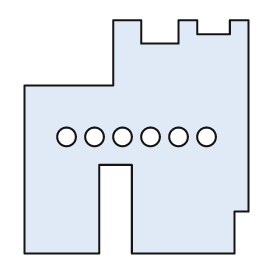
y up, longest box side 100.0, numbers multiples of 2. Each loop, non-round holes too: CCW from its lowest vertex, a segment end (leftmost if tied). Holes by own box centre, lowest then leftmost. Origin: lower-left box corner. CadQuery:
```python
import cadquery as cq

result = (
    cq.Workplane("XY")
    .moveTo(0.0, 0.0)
    .lineTo(32.0, 0.0)
    .lineTo(32.0, 38.0)
    .lineTo(46.0, 38.0)
    .lineTo(46.0, 0.0)
    .lineTo(90.0, 0.0)
    .lineTo(90.0, 18.0)
    .lineTo(96.0, 18.0)
    .lineTo(96.0, 100.0)
    .lineTo(88.0, 100.0)
    .lineTo(88.0, 94.0)
    .lineTo(74.0, 94.0)
    .lineTo(74.0, 100.0)
    .lineTo(66.0, 100.0)
    .lineTo(66.0, 90.0)
    .lineTo(50.0, 90.0)
    .lineTo(50.0, 100.0)
    .lineTo(38.0, 100.0)
    .lineTo(38.0, 72.0)
    .lineTo(0.0, 72.0)
    .close()
    .moveTo(18.0, 50.0)
    .circle(4.0)
    .moveTo(30.0, 50.0)
    .circle(4.0)
    .moveTo(42.0, 50.0)
    .circle(4.0)
    .moveTo(54.0, 50.0)
    .circle(4.0)
    .moveTo(66.0, 50.0)
    .circle(4.0)
    .moveTo(78.0, 50.0)
    .circle(4.0)
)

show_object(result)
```